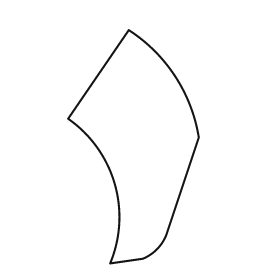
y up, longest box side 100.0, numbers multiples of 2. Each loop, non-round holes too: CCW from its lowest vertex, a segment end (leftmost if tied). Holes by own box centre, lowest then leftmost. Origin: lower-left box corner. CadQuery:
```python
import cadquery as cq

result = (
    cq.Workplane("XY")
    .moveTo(18.0, 0.0)
    .lineTo(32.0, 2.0)
    .threePointArc((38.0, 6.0), (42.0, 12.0))
    .lineTo(56.0, 54.0)
    .threePointArc((46.0, 80.0), (26.0, 100.0))
    .lineTo(0.0, 62.0)
    .threePointArc((20.0, 34.0), (18.0, 0.0))
    .close()
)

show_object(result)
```